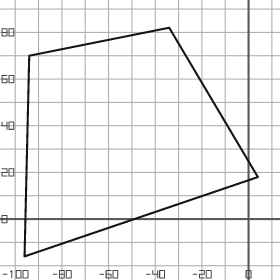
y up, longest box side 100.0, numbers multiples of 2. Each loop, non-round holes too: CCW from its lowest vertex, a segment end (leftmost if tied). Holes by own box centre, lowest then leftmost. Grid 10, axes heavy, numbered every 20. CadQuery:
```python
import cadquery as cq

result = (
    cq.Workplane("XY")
    .moveTo(-96.0, -16.0)
    .lineTo(4.0, 18.0)
    .lineTo(-34.0, 82.0)
    .lineTo(-94.0, 70.0)
    .close()
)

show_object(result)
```